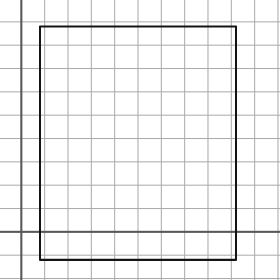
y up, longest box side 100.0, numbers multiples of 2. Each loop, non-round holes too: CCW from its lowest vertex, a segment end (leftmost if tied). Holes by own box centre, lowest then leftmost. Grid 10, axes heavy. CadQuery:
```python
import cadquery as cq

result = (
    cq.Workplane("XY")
    .moveTo(8.0, -12.0)
    .lineTo(92.0, -12.0)
    .lineTo(92.0, 88.0)
    .lineTo(8.0, 88.0)
    .close()
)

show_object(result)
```